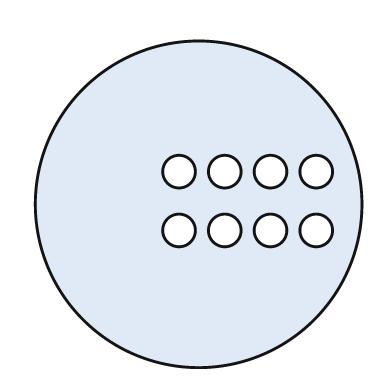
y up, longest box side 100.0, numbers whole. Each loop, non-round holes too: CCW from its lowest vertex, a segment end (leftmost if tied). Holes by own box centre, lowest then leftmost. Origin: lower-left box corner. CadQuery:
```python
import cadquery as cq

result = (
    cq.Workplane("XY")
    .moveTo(50.0, 50.0)
    .circle(50.0)
    .moveTo(44.0, 42.0)
    .circle(5.0)
    .moveTo(58.0, 42.0)
    .circle(5.0)
    .moveTo(72.0, 42.0)
    .circle(5.0)
    .moveTo(86.0, 42.0)
    .circle(5.0)
    .moveTo(44.0, 60.0)
    .circle(5.0)
    .moveTo(58.0, 60.0)
    .circle(5.0)
    .moveTo(72.0, 60.0)
    .circle(5.0)
    .moveTo(86.0, 60.0)
    .circle(5.0)
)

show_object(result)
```